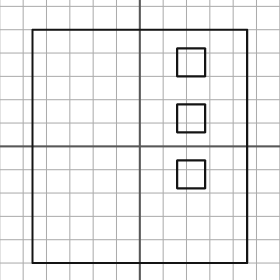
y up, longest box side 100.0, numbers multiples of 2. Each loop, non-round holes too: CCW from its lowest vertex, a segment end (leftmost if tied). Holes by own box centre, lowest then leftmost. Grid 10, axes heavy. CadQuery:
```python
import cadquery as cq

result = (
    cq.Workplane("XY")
    .moveTo(-46.0, -50.0)
    .lineTo(46.0, -50.0)
    .lineTo(46.0, 50.0)
    .lineTo(-46.0, 50.0)
    .close()
    .moveTo(16.0, -18.0)
    .lineTo(28.0, -18.0)
    .lineTo(28.0, -6.0)
    .lineTo(16.0, -6.0)
    .close()
    .moveTo(16.0, 6.0)
    .lineTo(28.0, 6.0)
    .lineTo(28.0, 18.0)
    .lineTo(16.0, 18.0)
    .close()
    .moveTo(16.0, 30.0)
    .lineTo(28.0, 30.0)
    .lineTo(28.0, 42.0)
    .lineTo(16.0, 42.0)
    .close()
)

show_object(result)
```